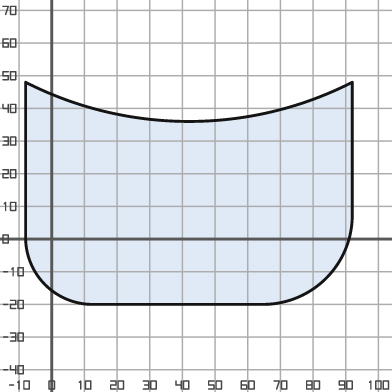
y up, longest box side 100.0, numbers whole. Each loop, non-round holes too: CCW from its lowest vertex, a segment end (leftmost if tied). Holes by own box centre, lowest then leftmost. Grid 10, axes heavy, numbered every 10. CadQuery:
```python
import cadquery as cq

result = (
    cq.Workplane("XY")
    .moveTo(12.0, -20.0)
    .lineTo(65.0, -20.0)
    .threePointArc((84.0, -12.0), (92.0, 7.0))
    .lineTo(92.0, 48.0)
    .threePointArc((42.0, 36.0), (-8.0, 48.0))
    .lineTo(-8.0, 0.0)
    .threePointArc((-2.0, -14.0), (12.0, -20.0))
    .close()
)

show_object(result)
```